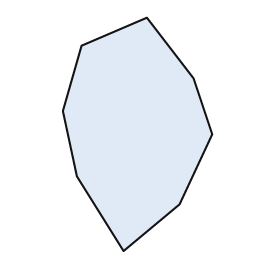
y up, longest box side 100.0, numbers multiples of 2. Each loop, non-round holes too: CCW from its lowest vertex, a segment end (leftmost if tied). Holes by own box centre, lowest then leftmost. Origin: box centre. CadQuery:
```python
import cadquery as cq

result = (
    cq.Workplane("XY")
    .moveTo(-6.0, -50.0)
    .lineTo(18.0, -30.0)
    .lineTo(32.0, 0.0)
    .lineTo(24.0, 24.0)
    .lineTo(4.0, 50.0)
    .lineTo(-24.0, 38.0)
    .lineTo(-32.0, 10.0)
    .lineTo(-26.0, -18.0)
    .close()
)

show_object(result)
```